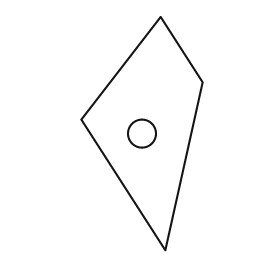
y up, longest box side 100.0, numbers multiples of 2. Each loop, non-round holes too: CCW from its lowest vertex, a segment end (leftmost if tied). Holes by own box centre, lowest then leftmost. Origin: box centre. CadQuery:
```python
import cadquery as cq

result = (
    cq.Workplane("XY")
    .moveTo(10.0, -50.0)
    .lineTo(26.0, 22.0)
    .lineTo(8.0, 50.0)
    .lineTo(-26.0, 6.0)
    .close()
    .moveTo(0.0, 0.0)
    .circle(6.0)
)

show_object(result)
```